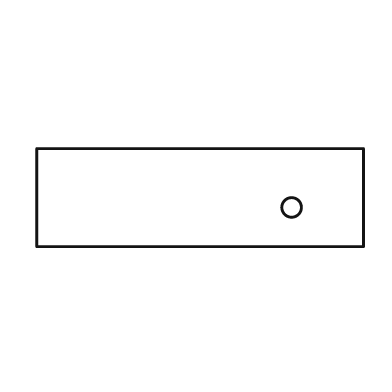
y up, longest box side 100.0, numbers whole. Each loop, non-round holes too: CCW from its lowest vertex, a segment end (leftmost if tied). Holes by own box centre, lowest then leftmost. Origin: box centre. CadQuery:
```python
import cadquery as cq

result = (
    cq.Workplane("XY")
    .moveTo(-50.0, -15.0)
    .lineTo(50.0, -15.0)
    .lineTo(50.0, 15.0)
    .lineTo(-50.0, 15.0)
    .close()
    .moveTo(28.0, -3.0)
    .circle(3.0)
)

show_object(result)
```